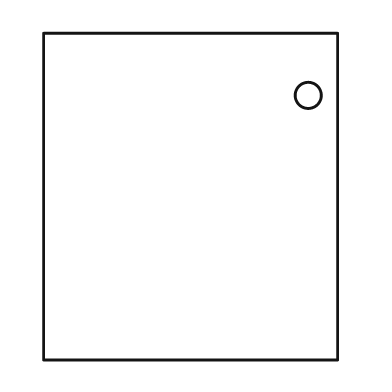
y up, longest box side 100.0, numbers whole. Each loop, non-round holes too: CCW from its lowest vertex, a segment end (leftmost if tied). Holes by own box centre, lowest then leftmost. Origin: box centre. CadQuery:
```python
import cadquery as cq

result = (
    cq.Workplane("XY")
    .moveTo(-45.0, -50.0)
    .lineTo(45.0, -50.0)
    .lineTo(45.0, 50.0)
    .lineTo(-45.0, 50.0)
    .close()
    .moveTo(36.0, 31.0)
    .circle(4.0)
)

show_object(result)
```